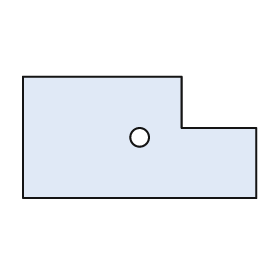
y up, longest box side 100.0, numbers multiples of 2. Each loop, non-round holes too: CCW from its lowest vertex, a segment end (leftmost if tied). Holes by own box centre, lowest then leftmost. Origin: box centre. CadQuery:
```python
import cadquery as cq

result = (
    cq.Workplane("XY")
    .moveTo(-50.0, -26.0)
    .lineTo(50.0, -26.0)
    .lineTo(50.0, 4.0)
    .lineTo(18.0, 4.0)
    .lineTo(18.0, 26.0)
    .lineTo(-50.0, 26.0)
    .close()
    .moveTo(0.0, 0.0)
    .circle(4.0)
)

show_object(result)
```